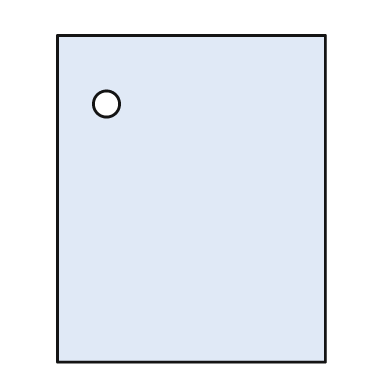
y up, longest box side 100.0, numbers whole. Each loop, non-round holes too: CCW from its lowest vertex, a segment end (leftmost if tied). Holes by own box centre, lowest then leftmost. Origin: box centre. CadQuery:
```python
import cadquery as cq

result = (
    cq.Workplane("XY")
    .moveTo(-41.0, -50.0)
    .lineTo(41.0, -50.0)
    .lineTo(41.0, 50.0)
    .lineTo(-41.0, 50.0)
    .close()
    .moveTo(-26.0, 29.0)
    .circle(4.0)
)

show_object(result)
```